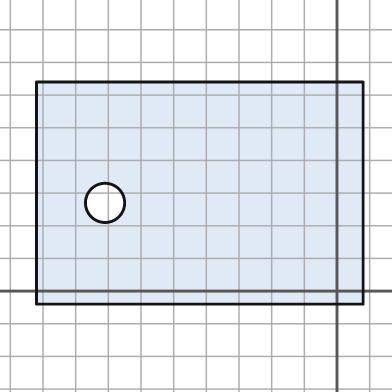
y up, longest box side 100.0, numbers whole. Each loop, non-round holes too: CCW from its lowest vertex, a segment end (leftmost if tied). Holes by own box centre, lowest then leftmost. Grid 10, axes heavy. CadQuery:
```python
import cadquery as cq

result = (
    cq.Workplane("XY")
    .moveTo(-92.0, -4.0)
    .lineTo(8.0, -4.0)
    .lineTo(8.0, 64.0)
    .lineTo(-92.0, 64.0)
    .close()
    .moveTo(-71.0, 27.0)
    .circle(6.0)
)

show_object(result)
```